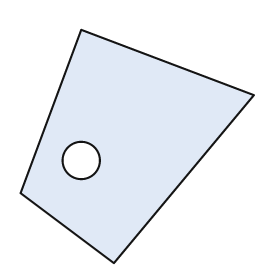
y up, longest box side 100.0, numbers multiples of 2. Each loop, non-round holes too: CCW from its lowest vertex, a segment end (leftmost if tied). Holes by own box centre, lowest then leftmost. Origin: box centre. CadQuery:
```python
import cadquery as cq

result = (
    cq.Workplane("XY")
    .moveTo(-10.0, -50.0)
    .lineTo(50.0, 22.0)
    .lineTo(-24.0, 50.0)
    .lineTo(-50.0, -20.0)
    .close()
    .moveTo(-24.0, -6.0)
    .circle(8.0)
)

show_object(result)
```